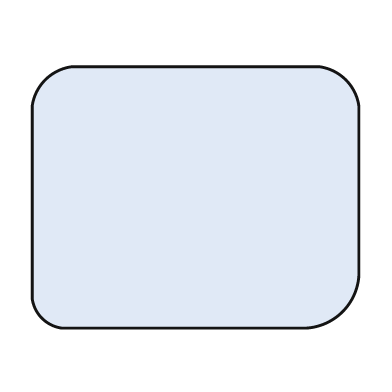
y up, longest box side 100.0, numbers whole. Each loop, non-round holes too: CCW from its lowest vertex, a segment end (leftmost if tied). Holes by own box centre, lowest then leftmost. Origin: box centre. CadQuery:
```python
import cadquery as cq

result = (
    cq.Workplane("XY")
    .moveTo(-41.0, -40.0)
    .lineTo(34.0, -40.0)
    .threePointArc((45.0, -35.0), (50.0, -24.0))
    .lineTo(50.0, 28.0)
    .threePointArc((46.0, 36.0), (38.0, 40.0))
    .lineTo(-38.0, 40.0)
    .threePointArc((-46.0, 36.0), (-50.0, 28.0))
    .lineTo(-50.0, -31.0)
    .threePointArc((-47.0, -37.0), (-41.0, -40.0))
    .close()
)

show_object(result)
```